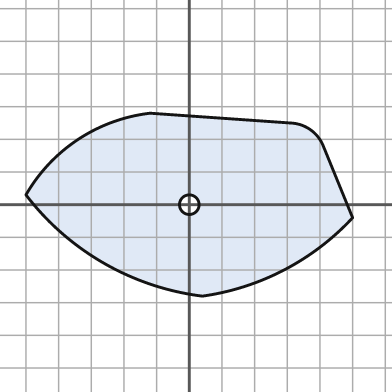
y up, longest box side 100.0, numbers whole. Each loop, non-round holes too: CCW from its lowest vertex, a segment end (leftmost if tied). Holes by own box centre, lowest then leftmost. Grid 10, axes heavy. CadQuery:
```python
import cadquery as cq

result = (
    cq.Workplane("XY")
    .moveTo(4.0, -28.0)
    .threePointArc((29.0, -20.0), (50.0, -4.0))
    .lineTo(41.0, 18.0)
    .threePointArc((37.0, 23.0), (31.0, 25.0))
    .lineTo(-12.0, 28.0)
    .threePointArc((-34.0, 20.0), (-50.0, 3.0))
    .threePointArc((-26.0, -18.0), (4.0, -28.0))
    .close()
    .moveTo(0.0, 0.0)
    .circle(3.0)
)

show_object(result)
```